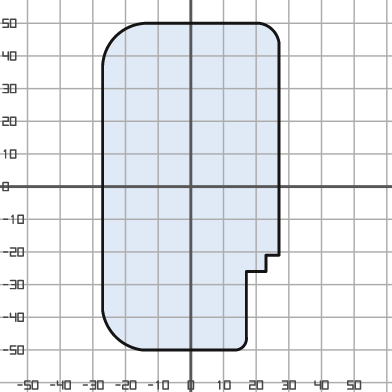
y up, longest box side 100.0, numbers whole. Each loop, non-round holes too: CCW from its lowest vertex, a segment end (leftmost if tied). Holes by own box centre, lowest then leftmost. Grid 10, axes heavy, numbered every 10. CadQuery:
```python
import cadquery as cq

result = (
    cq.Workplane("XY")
    .moveTo(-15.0, -50.0)
    .lineTo(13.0, -50.0)
    .threePointArc((16.0, -49.0), (17.0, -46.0))
    .lineTo(17.0, -26.0)
    .lineTo(23.0, -26.0)
    .lineTo(23.0, -21.0)
    .lineTo(27.0, -21.0)
    .lineTo(27.0, 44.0)
    .threePointArc((25.0, 48.0), (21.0, 50.0))
    .lineTo(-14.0, 50.0)
    .threePointArc((-23.0, 46.0), (-27.0, 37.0))
    .lineTo(-27.0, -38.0)
    .threePointArc((-23.0, -46.0), (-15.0, -50.0))
    .close()
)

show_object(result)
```